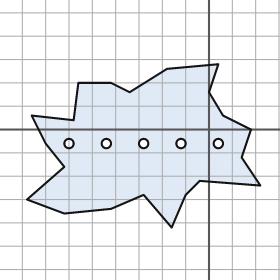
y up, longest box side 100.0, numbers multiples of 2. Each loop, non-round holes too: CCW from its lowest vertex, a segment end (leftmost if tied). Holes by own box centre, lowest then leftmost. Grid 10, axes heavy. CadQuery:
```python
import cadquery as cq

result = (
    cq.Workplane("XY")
    .moveTo(-16.0, -42.0)
    .lineTo(-10.0, -28.0)
    .lineTo(-4.0, -22.0)
    .lineTo(22.0, -24.0)
    .lineTo(14.0, -12.0)
    .lineTo(18.0, 0.0)
    .lineTo(6.0, 6.0)
    .lineTo(0.0, 16.0)
    .lineTo(4.0, 28.0)
    .lineTo(-18.0, 26.0)
    .lineTo(-34.0, 16.0)
    .lineTo(-42.0, 20.0)
    .lineTo(-56.0, 20.0)
    .lineTo(-58.0, 4.0)
    .lineTo(-76.0, 6.0)
    .lineTo(-70.0, -6.0)
    .lineTo(-62.0, -16.0)
    .lineTo(-78.0, -30.0)
    .lineTo(-62.0, -36.0)
    .lineTo(-42.0, -34.0)
    .lineTo(-28.0, -28.0)
    .close()
    .moveTo(-60.0, -6.0)
    .circle(2.0)
    .moveTo(-44.0, -6.0)
    .circle(2.0)
    .moveTo(-28.0, -6.0)
    .circle(2.0)
    .moveTo(-12.0, -6.0)
    .circle(2.0)
    .moveTo(4.0, -6.0)
    .circle(2.0)
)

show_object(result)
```